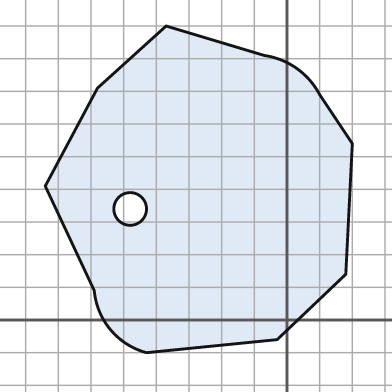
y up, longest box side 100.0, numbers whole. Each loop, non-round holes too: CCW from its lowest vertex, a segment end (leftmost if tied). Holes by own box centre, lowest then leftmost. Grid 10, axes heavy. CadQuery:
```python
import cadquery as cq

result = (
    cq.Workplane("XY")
    .moveTo(-43.0, -10.0)
    .lineTo(-3.0, -6.0)
    .lineTo(18.0, 14.0)
    .lineTo(20.0, 54.0)
    .lineTo(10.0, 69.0)
    .threePointArc((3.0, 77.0), (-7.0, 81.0))
    .lineTo(-37.0, 90.0)
    .lineTo(-58.0, 71.0)
    .lineTo(-74.0, 41.0)
    .lineTo(-59.0, 9.0)
    .threePointArc((-54.0, -3.0), (-43.0, -10.0))
    .close()
    .moveTo(-48.0, 34.0)
    .circle(5.0)
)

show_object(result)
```